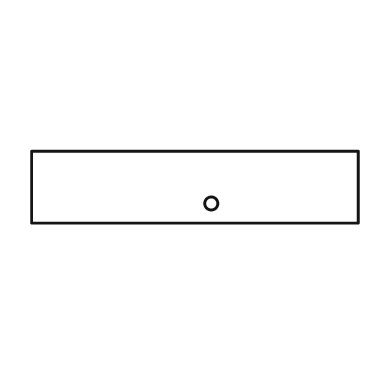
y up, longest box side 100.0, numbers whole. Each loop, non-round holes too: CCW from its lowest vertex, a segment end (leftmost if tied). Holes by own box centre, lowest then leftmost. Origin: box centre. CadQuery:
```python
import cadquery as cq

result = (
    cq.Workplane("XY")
    .moveTo(-50.0, -11.0)
    .lineTo(50.0, -11.0)
    .lineTo(50.0, 11.0)
    .lineTo(-50.0, 11.0)
    .close()
    .moveTo(5.0, -5.0)
    .circle(2.0)
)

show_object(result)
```